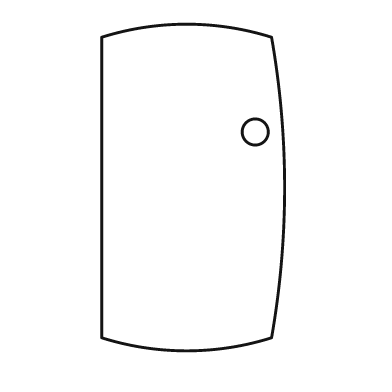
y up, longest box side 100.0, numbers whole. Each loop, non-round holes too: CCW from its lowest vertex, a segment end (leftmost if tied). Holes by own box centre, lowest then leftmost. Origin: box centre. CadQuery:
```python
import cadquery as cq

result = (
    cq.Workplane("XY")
    .moveTo(-28.0, -46.0)
    .threePointArc((-2.0, -50.0), (24.0, -46.0))
    .threePointArc((28.0, 0.0), (24.0, 46.0))
    .threePointArc((-2.0, 50.0), (-28.0, 46.0))
    .close()
    .moveTo(19.0, 17.0)
    .circle(4.0)
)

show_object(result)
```